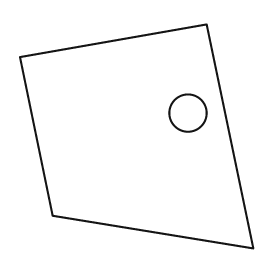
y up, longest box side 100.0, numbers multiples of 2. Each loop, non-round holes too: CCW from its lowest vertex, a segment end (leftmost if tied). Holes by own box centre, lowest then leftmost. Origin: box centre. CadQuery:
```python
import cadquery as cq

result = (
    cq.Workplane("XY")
    .moveTo(50.0, -48.0)
    .lineTo(30.0, 48.0)
    .lineTo(-50.0, 34.0)
    .lineTo(-36.0, -34.0)
    .close()
    .moveTo(22.0, 10.0)
    .circle(8.0)
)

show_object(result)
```